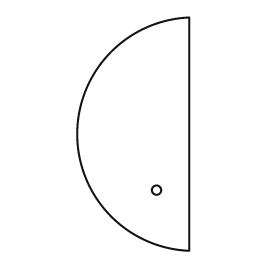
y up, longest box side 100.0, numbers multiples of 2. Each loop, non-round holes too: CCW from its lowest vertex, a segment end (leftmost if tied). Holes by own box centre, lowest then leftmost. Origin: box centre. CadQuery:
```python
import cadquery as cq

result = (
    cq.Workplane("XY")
    .moveTo(24.0, -50.0)
    .lineTo(24.0, 50.0)
    .threePointArc((-24.0, 0.0), (24.0, -50.0))
    .close()
    .moveTo(10.0, -24.0)
    .circle(2.0)
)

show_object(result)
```